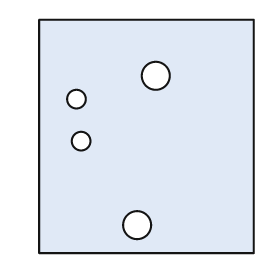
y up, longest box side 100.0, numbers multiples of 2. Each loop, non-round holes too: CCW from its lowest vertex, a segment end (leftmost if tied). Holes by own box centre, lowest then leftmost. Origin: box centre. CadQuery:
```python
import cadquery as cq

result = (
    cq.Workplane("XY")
    .moveTo(-46.0, -50.0)
    .lineTo(46.0, -50.0)
    .lineTo(46.0, 50.0)
    .lineTo(-46.0, 50.0)
    .close()
    .moveTo(-4.0, -38.0)
    .circle(6.0)
    .moveTo(-28.0, -2.0)
    .circle(4.0)
    .moveTo(-30.0, 16.0)
    .circle(4.0)
    .moveTo(4.0, 26.0)
    .circle(6.0)
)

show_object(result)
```